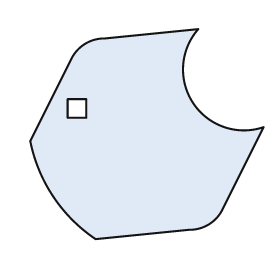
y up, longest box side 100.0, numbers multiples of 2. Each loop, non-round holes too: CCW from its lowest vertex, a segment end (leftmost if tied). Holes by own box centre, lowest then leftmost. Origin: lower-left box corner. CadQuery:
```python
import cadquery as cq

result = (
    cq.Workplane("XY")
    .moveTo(28.0, 0.0)
    .lineTo(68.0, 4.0)
    .threePointArc((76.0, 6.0), (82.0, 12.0))
    .lineTo(100.0, 48.0)
    .threePointArc((70.0, 58.0), (72.0, 90.0))
    .lineTo(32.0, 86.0)
    .threePointArc((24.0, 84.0), (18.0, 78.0))
    .lineTo(0.0, 42.0)
    .threePointArc((10.0, 18.0), (28.0, 0.0))
    .close()
    .moveTo(16.0, 52.0)
    .lineTo(24.0, 52.0)
    .lineTo(24.0, 60.0)
    .lineTo(16.0, 60.0)
    .close()
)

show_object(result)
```